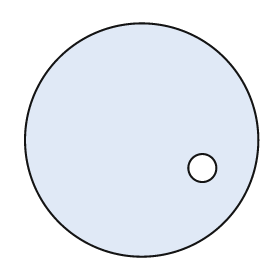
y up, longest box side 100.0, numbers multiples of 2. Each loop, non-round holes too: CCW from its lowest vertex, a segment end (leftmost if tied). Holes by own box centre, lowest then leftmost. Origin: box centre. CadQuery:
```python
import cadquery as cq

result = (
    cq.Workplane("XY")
    .moveTo(0.0, 0.0)
    .circle(50.0)
    .moveTo(26.0, -12.0)
    .circle(6.0)
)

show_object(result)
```